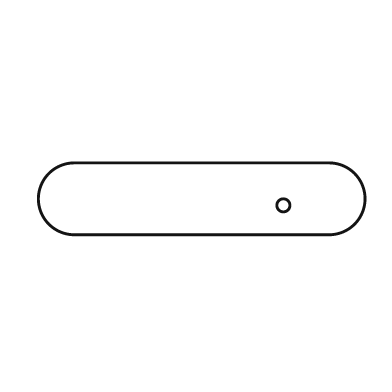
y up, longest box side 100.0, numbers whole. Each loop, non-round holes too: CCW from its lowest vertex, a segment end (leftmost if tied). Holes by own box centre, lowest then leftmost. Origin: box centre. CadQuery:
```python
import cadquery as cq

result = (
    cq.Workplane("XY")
    .moveTo(-39.0, -11.0)
    .lineTo(39.0, -11.0)
    .threePointArc((50.0, 0.0), (39.0, 11.0))
    .lineTo(-39.0, 11.0)
    .threePointArc((-50.0, 0.0), (-39.0, -11.0))
    .close()
    .moveTo(25.0, -2.0)
    .circle(2.0)
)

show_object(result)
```